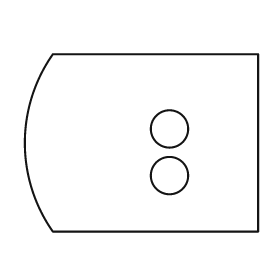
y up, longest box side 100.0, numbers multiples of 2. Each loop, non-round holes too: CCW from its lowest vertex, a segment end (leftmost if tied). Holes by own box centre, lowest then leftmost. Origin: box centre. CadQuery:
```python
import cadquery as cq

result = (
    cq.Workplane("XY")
    .moveTo(-38.0, -38.0)
    .lineTo(50.0, -38.0)
    .lineTo(50.0, 38.0)
    .lineTo(-38.0, 38.0)
    .threePointArc((-50.0, 0.0), (-38.0, -38.0))
    .close()
    .moveTo(12.0, -14.0)
    .circle(8.0)
    .moveTo(12.0, 6.0)
    .circle(8.0)
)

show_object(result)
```